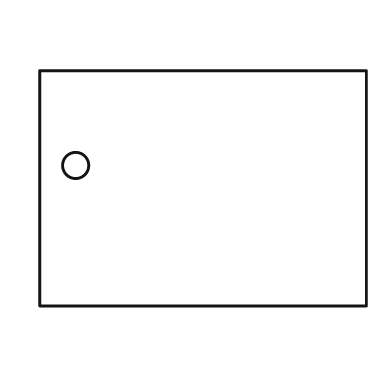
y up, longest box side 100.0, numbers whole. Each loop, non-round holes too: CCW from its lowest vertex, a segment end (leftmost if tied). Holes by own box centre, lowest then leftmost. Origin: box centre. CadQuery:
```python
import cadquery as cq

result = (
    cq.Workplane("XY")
    .moveTo(-50.0, -36.0)
    .lineTo(50.0, -36.0)
    .lineTo(50.0, 36.0)
    .lineTo(-50.0, 36.0)
    .close()
    .moveTo(-39.0, 7.0)
    .circle(4.0)
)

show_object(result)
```